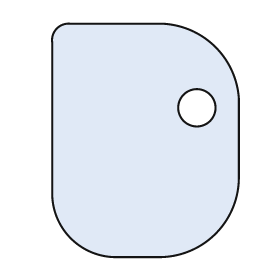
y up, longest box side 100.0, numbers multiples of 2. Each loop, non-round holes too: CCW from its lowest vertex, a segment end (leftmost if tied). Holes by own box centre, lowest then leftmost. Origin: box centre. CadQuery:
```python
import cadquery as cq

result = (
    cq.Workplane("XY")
    .moveTo(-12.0, -50.0)
    .lineTo(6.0, -50.0)
    .threePointArc((30.0, -40.0), (40.0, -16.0))
    .lineTo(40.0, 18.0)
    .threePointArc((30.0, 40.0), (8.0, 50.0))
    .lineTo(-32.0, 50.0)
    .threePointArc((-38.0, 48.0), (-40.0, 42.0))
    .lineTo(-40.0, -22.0)
    .threePointArc((-32.0, -42.0), (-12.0, -50.0))
    .close()
    .moveTo(22.0, 14.0)
    .circle(8.0)
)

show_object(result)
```